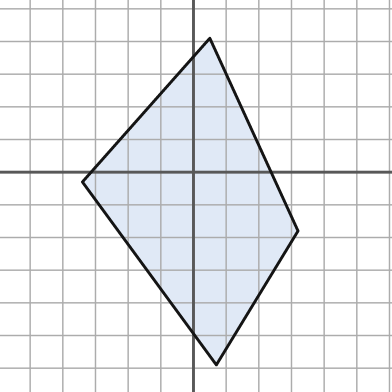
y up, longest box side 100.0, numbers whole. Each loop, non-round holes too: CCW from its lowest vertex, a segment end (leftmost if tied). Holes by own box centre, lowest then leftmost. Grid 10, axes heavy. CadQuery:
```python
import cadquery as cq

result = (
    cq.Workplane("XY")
    .moveTo(7.0, -59.0)
    .lineTo(32.0, -18.0)
    .lineTo(5.0, 41.0)
    .lineTo(-34.0, -3.0)
    .close()
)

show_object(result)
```